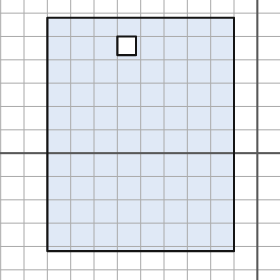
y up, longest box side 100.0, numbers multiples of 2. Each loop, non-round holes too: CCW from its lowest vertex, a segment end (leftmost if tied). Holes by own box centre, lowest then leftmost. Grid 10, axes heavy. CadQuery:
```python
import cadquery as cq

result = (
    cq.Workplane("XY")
    .moveTo(-90.0, -42.0)
    .lineTo(-10.0, -42.0)
    .lineTo(-10.0, 58.0)
    .lineTo(-90.0, 58.0)
    .close()
    .moveTo(-60.0, 42.0)
    .lineTo(-52.0, 42.0)
    .lineTo(-52.0, 50.0)
    .lineTo(-60.0, 50.0)
    .close()
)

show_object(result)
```